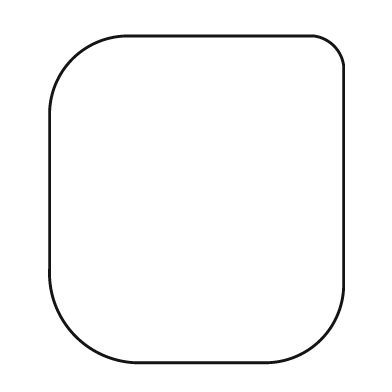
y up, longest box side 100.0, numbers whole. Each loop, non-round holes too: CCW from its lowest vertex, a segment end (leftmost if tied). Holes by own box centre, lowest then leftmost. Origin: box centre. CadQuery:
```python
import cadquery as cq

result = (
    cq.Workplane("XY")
    .moveTo(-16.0, -50.0)
    .lineTo(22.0, -50.0)
    .threePointArc((38.0, -43.0), (45.0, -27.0))
    .lineTo(45.0, 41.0)
    .threePointArc((42.0, 47.0), (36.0, 50.0))
    .lineTo(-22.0, 50.0)
    .threePointArc((-38.0, 43.0), (-45.0, 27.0))
    .lineTo(-45.0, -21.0)
    .threePointArc((-37.0, -42.0), (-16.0, -50.0))
    .close()
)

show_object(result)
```